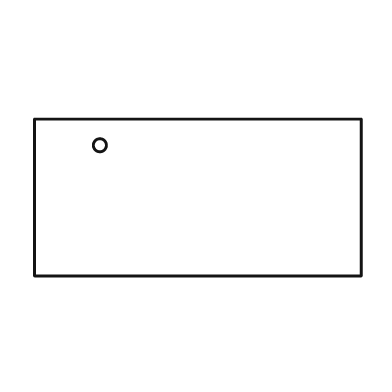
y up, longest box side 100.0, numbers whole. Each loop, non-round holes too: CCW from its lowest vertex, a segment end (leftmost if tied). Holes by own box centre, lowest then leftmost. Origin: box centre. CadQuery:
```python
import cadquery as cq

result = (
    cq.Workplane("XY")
    .moveTo(-50.0, -24.0)
    .lineTo(50.0, -24.0)
    .lineTo(50.0, 24.0)
    .lineTo(-50.0, 24.0)
    .close()
    .moveTo(-30.0, 16.0)
    .circle(2.0)
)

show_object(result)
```